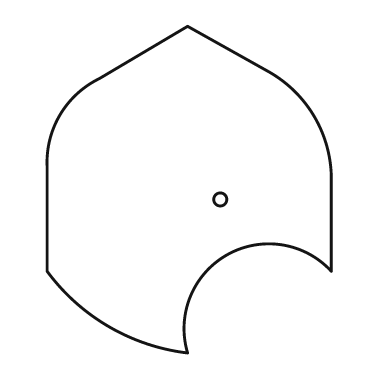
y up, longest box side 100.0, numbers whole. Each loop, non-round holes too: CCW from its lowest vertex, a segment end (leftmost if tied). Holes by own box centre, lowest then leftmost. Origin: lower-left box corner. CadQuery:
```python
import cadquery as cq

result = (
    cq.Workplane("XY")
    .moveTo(43.0, 0.0)
    .threePointArc((55.0, 30.0), (87.0, 25.0))
    .lineTo(87.0, 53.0)
    .threePointArc((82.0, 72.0), (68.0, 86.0))
    .lineTo(43.0, 100.0)
    .lineTo(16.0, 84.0)
    .threePointArc((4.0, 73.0), (0.0, 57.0))
    .lineTo(0.0, 25.0)
    .threePointArc((19.0, 8.0), (43.0, 0.0))
    .close()
    .moveTo(53.0, 47.0)
    .circle(2.0)
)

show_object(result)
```